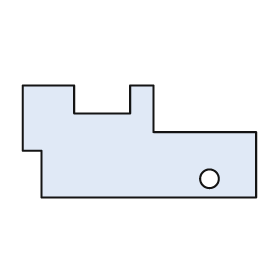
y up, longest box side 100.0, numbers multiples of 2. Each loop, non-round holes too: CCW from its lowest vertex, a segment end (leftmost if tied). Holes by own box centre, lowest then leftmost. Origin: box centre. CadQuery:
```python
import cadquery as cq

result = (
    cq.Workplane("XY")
    .moveTo(-42.0, -24.0)
    .lineTo(50.0, -24.0)
    .lineTo(50.0, 4.0)
    .lineTo(6.0, 4.0)
    .lineTo(6.0, 24.0)
    .lineTo(-4.0, 24.0)
    .lineTo(-4.0, 12.0)
    .lineTo(-28.0, 12.0)
    .lineTo(-28.0, 24.0)
    .lineTo(-50.0, 24.0)
    .lineTo(-50.0, -4.0)
    .lineTo(-42.0, -4.0)
    .close()
    .moveTo(30.0, -16.0)
    .circle(4.0)
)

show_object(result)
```